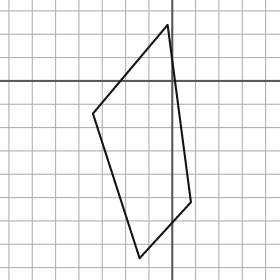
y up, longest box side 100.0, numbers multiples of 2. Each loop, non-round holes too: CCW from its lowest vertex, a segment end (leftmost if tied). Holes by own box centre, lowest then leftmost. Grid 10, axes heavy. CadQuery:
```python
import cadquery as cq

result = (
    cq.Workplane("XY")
    .moveTo(-14.0, -76.0)
    .lineTo(8.0, -52.0)
    .lineTo(-2.0, 24.0)
    .lineTo(-34.0, -14.0)
    .close()
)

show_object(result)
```